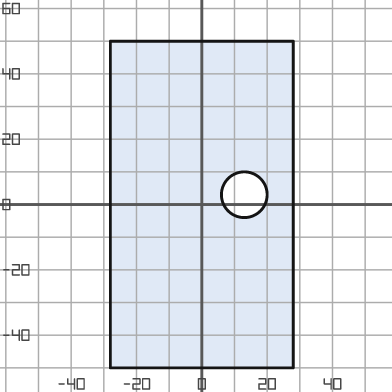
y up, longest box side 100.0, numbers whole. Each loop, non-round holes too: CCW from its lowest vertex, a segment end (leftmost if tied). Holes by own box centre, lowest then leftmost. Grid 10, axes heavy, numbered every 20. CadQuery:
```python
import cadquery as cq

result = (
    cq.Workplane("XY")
    .moveTo(-28.0, -50.0)
    .lineTo(28.0, -50.0)
    .lineTo(28.0, 50.0)
    .lineTo(-28.0, 50.0)
    .close()
    .moveTo(13.0, 3.0)
    .circle(7.0)
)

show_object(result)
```